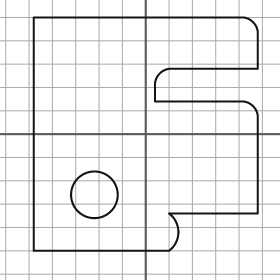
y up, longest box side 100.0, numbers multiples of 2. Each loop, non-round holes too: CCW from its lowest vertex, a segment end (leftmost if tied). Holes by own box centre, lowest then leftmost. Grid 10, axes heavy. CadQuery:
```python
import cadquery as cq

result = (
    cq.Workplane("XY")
    .moveTo(-48.0, -50.0)
    .lineTo(10.0, -50.0)
    .threePointArc((14.0, -42.0), (10.0, -34.0))
    .lineTo(48.0, -34.0)
    .lineTo(48.0, 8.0)
    .threePointArc((46.0, 12.0), (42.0, 14.0))
    .lineTo(4.0, 14.0)
    .lineTo(4.0, 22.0)
    .threePointArc((6.0, 26.0), (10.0, 28.0))
    .lineTo(48.0, 28.0)
    .lineTo(48.0, 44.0)
    .threePointArc((46.0, 48.0), (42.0, 50.0))
    .lineTo(-48.0, 50.0)
    .close()
    .moveTo(-22.0, -26.0)
    .circle(10.0)
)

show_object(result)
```